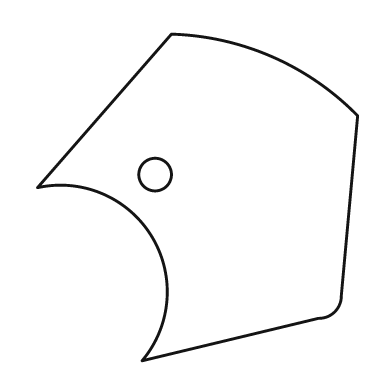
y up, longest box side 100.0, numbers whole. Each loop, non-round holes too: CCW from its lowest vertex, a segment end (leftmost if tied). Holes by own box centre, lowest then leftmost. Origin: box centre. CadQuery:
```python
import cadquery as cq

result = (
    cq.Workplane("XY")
    .moveTo(-17.0, -50.0)
    .lineTo(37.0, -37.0)
    .threePointArc((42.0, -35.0), (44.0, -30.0))
    .lineTo(49.0, 25.0)
    .threePointArc((23.0, 43.0), (-8.0, 50.0))
    .lineTo(-49.0, 3.0)
    .threePointArc((-14.0, -12.0), (-17.0, -50.0))
    .close()
    .moveTo(-13.0, 7.0)
    .circle(5.0)
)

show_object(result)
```